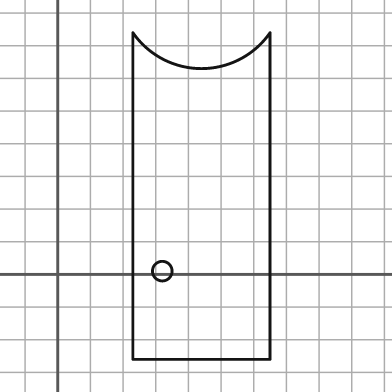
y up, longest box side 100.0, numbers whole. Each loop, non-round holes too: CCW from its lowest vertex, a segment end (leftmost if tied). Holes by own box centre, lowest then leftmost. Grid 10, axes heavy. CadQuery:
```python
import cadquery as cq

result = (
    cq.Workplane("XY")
    .moveTo(23.0, -26.0)
    .lineTo(65.0, -26.0)
    .lineTo(65.0, 74.0)
    .threePointArc((44.0, 63.0), (23.0, 74.0))
    .close()
    .moveTo(32.0, 1.0)
    .circle(3.0)
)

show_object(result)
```